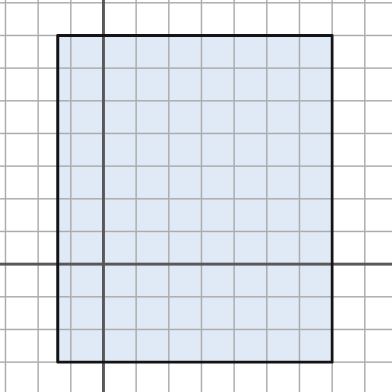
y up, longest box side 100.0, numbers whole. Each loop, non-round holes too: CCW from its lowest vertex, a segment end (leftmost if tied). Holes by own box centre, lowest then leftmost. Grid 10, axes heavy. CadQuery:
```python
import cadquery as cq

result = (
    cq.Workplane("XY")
    .moveTo(-14.0, -30.0)
    .lineTo(70.0, -30.0)
    .lineTo(70.0, 70.0)
    .lineTo(-14.0, 70.0)
    .close()
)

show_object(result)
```